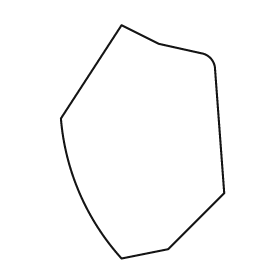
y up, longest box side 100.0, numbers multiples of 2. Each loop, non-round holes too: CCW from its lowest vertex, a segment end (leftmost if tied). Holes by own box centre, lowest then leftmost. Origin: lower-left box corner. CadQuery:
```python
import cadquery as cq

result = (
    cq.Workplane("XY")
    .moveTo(26.0, 0.0)
    .lineTo(46.0, 4.0)
    .lineTo(70.0, 28.0)
    .lineTo(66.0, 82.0)
    .threePointArc((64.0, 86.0), (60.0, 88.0))
    .lineTo(42.0, 92.0)
    .lineTo(26.0, 100.0)
    .lineTo(0.0, 60.0)
    .threePointArc((8.0, 28.0), (26.0, 0.0))
    .close()
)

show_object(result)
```